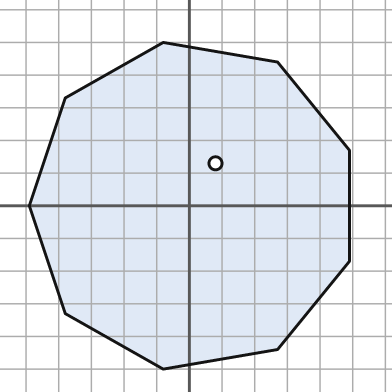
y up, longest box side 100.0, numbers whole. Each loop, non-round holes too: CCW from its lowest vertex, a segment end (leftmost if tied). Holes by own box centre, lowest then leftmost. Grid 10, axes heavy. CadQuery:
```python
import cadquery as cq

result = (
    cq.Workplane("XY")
    .moveTo(-8.0, -50.0)
    .lineTo(27.0, -44.0)
    .lineTo(49.0, -17.0)
    .lineTo(49.0, 17.0)
    .lineTo(27.0, 44.0)
    .lineTo(-8.0, 50.0)
    .lineTo(-38.0, 33.0)
    .lineTo(-49.0, 0.0)
    .lineTo(-38.0, -33.0)
    .close()
    .moveTo(8.0, 13.0)
    .circle(2.0)
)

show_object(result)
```